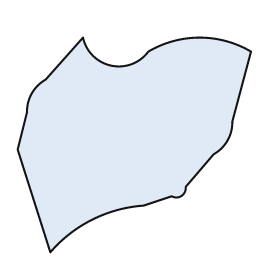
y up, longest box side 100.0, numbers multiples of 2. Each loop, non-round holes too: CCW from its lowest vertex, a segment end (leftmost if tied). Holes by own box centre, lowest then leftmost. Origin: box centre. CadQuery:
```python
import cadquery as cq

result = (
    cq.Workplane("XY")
    .moveTo(-36.0, -46.0)
    .threePointArc((-18.0, -32.0), (4.0, -26.0))
    .lineTo(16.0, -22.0)
    .threePointArc((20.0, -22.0), (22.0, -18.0))
    .lineTo(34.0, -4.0)
    .threePointArc((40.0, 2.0), (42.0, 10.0))
    .lineTo(50.0, 40.0)
    .threePointArc((28.0, 46.0), (6.0, 40.0))
    .threePointArc((-10.0, 34.0), (-22.0, 46.0))
    .lineTo(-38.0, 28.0)
    .threePointArc((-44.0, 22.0), (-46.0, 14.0))
    .lineTo(-50.0, -2.0)
    .close()
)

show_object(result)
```